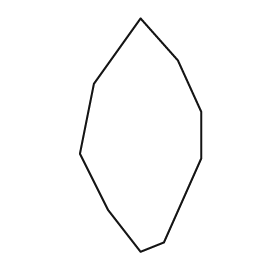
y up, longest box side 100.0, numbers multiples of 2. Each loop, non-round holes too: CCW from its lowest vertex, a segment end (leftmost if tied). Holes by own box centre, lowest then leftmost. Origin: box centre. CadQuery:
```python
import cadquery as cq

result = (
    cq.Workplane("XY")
    .moveTo(0.0, -50.0)
    .lineTo(10.0, -46.0)
    .lineTo(26.0, -10.0)
    .lineTo(26.0, 10.0)
    .lineTo(16.0, 32.0)
    .lineTo(0.0, 50.0)
    .lineTo(-20.0, 22.0)
    .lineTo(-26.0, -8.0)
    .lineTo(-14.0, -32.0)
    .close()
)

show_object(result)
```